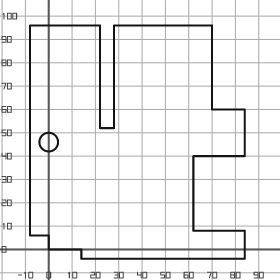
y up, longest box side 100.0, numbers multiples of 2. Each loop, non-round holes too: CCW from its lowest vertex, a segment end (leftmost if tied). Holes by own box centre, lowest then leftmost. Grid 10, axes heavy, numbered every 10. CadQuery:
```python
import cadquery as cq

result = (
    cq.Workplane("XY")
    .moveTo(14.0, -4.0)
    .lineTo(84.0, -4.0)
    .lineTo(84.0, 8.0)
    .lineTo(62.0, 8.0)
    .lineTo(62.0, 40.0)
    .lineTo(84.0, 40.0)
    .lineTo(84.0, 60.0)
    .lineTo(70.0, 60.0)
    .lineTo(70.0, 96.0)
    .lineTo(28.0, 96.0)
    .lineTo(28.0, 52.0)
    .lineTo(22.0, 52.0)
    .lineTo(22.0, 96.0)
    .lineTo(-8.0, 96.0)
    .lineTo(-8.0, 6.0)
    .lineTo(0.0, 6.0)
    .lineTo(0.0, 0.0)
    .lineTo(14.0, 0.0)
    .close()
    .moveTo(0.0, 46.0)
    .circle(4.0)
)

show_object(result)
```